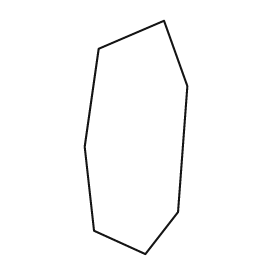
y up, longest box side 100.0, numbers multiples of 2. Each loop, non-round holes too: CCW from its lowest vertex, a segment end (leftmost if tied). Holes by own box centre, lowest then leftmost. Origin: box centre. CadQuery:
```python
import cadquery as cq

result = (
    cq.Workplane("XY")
    .moveTo(4.0, -50.0)
    .lineTo(18.0, -32.0)
    .lineTo(22.0, 22.0)
    .lineTo(12.0, 50.0)
    .lineTo(-16.0, 38.0)
    .lineTo(-22.0, -4.0)
    .lineTo(-18.0, -40.0)
    .close()
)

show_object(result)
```